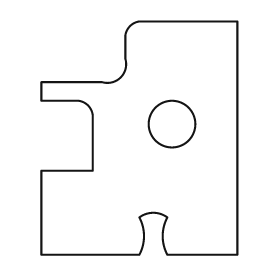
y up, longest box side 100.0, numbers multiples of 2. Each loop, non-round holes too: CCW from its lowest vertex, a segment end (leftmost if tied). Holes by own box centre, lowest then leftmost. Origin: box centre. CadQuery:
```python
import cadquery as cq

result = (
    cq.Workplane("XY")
    .moveTo(-42.0, -50.0)
    .lineTo(0.0, -50.0)
    .threePointArc((2.0, -42.0), (0.0, -34.0))
    .threePointArc((6.0, -32.0), (12.0, -34.0))
    .threePointArc((10.0, -42.0), (12.0, -50.0))
    .lineTo(42.0, -50.0)
    .lineTo(42.0, 50.0)
    .lineTo(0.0, 50.0)
    .threePointArc((-4.0, 48.0), (-6.0, 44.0))
    .lineTo(-6.0, 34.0)
    .threePointArc((-8.0, 26.0), (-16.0, 24.0))
    .lineTo(-42.0, 24.0)
    .lineTo(-42.0, 16.0)
    .lineTo(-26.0, 16.0)
    .threePointArc((-22.0, 14.0), (-20.0, 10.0))
    .lineTo(-20.0, -14.0)
    .lineTo(-42.0, -14.0)
    .close()
    .moveTo(14.0, 6.0)
    .circle(10.0)
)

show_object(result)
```